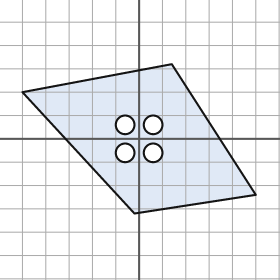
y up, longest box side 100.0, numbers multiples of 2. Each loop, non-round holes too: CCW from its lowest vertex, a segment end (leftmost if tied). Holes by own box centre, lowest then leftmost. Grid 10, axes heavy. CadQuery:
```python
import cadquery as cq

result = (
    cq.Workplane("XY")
    .moveTo(-2.0, -32.0)
    .lineTo(50.0, -24.0)
    .lineTo(14.0, 32.0)
    .lineTo(-50.0, 20.0)
    .close()
    .moveTo(-6.0, -6.0)
    .circle(4.0)
    .moveTo(6.0, -6.0)
    .circle(4.0)
    .moveTo(-6.0, 6.0)
    .circle(4.0)
    .moveTo(6.0, 6.0)
    .circle(4.0)
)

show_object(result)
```